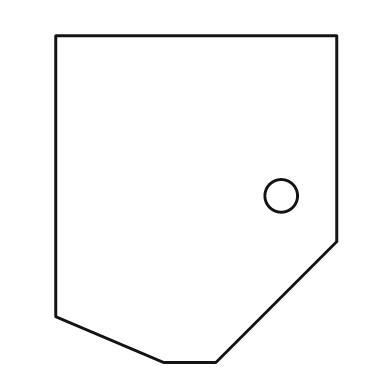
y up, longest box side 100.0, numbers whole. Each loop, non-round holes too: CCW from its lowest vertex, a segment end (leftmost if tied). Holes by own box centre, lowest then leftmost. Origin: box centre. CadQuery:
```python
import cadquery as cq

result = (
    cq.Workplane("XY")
    .moveTo(-10.0, -50.0)
    .lineTo(6.0, -50.0)
    .lineTo(43.0, -13.0)
    .lineTo(43.0, 50.0)
    .lineTo(-43.0, 50.0)
    .lineTo(-43.0, -36.0)
    .close()
    .moveTo(26.0, 1.0)
    .circle(5.0)
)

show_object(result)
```